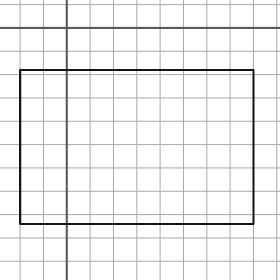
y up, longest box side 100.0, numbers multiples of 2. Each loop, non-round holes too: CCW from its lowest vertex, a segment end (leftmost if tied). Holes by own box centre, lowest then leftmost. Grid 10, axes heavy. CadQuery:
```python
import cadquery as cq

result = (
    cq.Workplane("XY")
    .moveTo(-20.0, -84.0)
    .lineTo(80.0, -84.0)
    .lineTo(80.0, -18.0)
    .lineTo(-20.0, -18.0)
    .close()
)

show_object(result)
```